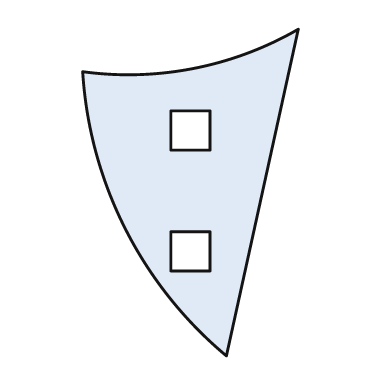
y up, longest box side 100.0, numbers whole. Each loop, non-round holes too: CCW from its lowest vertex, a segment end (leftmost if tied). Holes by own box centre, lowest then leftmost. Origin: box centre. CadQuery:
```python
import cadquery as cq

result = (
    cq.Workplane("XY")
    .moveTo(11.0, -50.0)
    .lineTo(33.0, 50.0)
    .threePointArc((1.0, 38.0), (-33.0, 37.0))
    .threePointArc((-20.0, -11.0), (11.0, -50.0))
    .close()
    .moveTo(-6.0, -24.0)
    .lineTo(6.0, -24.0)
    .lineTo(6.0, -12.0)
    .lineTo(-6.0, -12.0)
    .close()
    .moveTo(-6.0, 13.0)
    .lineTo(6.0, 13.0)
    .lineTo(6.0, 25.0)
    .lineTo(-6.0, 25.0)
    .close()
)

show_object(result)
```